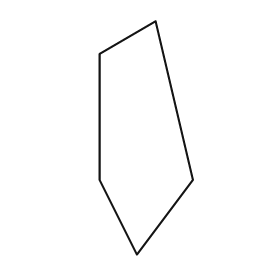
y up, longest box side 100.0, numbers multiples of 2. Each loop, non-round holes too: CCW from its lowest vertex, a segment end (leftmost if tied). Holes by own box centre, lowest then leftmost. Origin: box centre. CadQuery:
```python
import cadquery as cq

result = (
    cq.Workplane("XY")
    .moveTo(-4.0, -50.0)
    .lineTo(20.0, -18.0)
    .lineTo(4.0, 50.0)
    .lineTo(-20.0, 36.0)
    .lineTo(-20.0, -18.0)
    .close()
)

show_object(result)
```